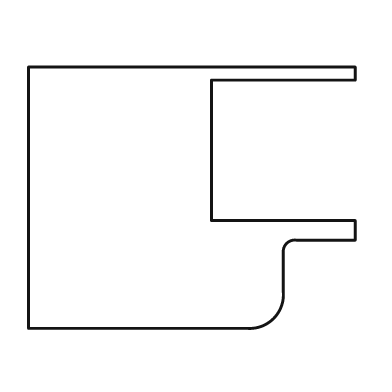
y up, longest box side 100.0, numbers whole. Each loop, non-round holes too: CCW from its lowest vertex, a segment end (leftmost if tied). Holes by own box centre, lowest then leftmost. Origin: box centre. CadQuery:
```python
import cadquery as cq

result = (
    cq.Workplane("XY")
    .moveTo(-50.0, -40.0)
    .lineTo(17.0, -40.0)
    .threePointArc((25.0, -37.0), (28.0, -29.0))
    .lineTo(28.0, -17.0)
    .threePointArc((29.0, -14.0), (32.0, -13.0))
    .lineTo(50.0, -13.0)
    .lineTo(50.0, -7.0)
    .lineTo(6.0, -7.0)
    .lineTo(6.0, 36.0)
    .lineTo(50.0, 36.0)
    .lineTo(50.0, 40.0)
    .lineTo(-50.0, 40.0)
    .close()
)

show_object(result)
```